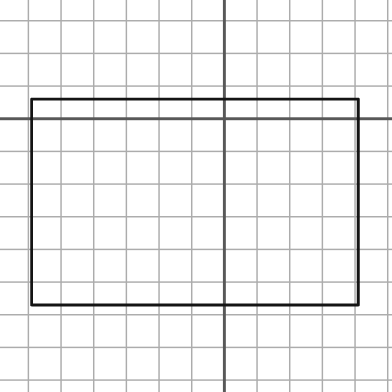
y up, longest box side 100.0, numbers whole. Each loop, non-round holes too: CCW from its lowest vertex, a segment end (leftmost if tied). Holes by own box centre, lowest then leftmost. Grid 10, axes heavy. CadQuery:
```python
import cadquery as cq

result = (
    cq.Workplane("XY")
    .moveTo(-59.0, -57.0)
    .lineTo(41.0, -57.0)
    .lineTo(41.0, 6.0)
    .lineTo(-59.0, 6.0)
    .close()
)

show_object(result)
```